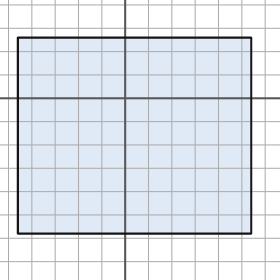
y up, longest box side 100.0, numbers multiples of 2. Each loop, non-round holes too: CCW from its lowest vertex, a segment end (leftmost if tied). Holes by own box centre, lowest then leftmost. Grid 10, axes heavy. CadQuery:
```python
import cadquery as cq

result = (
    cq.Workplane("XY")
    .moveTo(-46.0, -58.0)
    .lineTo(54.0, -58.0)
    .lineTo(54.0, 26.0)
    .lineTo(-46.0, 26.0)
    .close()
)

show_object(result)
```